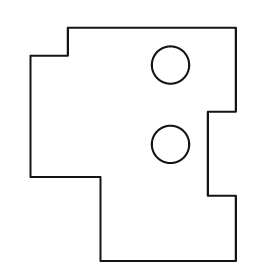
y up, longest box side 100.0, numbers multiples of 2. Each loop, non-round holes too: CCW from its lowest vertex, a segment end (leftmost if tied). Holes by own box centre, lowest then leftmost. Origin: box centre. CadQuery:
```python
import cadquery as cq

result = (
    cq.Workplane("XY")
    .moveTo(-14.0, -50.0)
    .lineTo(44.0, -50.0)
    .lineTo(44.0, -22.0)
    .lineTo(32.0, -22.0)
    .lineTo(32.0, 14.0)
    .lineTo(44.0, 14.0)
    .lineTo(44.0, 50.0)
    .lineTo(-28.0, 50.0)
    .lineTo(-28.0, 38.0)
    .lineTo(-44.0, 38.0)
    .lineTo(-44.0, -14.0)
    .lineTo(-14.0, -14.0)
    .close()
    .moveTo(16.0, 0.0)
    .circle(8.0)
    .moveTo(16.0, 34.0)
    .circle(8.0)
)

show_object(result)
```